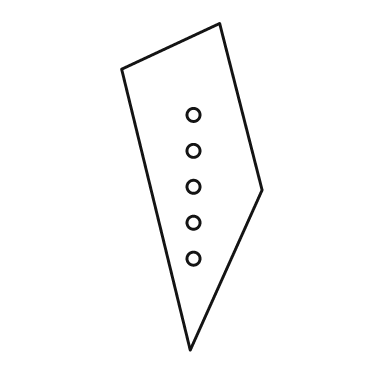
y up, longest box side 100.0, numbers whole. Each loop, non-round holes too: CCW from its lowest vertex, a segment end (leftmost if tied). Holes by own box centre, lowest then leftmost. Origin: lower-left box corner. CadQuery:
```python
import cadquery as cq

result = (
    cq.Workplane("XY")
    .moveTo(21.0, 0.0)
    .lineTo(43.0, 49.0)
    .lineTo(30.0, 100.0)
    .lineTo(0.0, 86.0)
    .close()
    .moveTo(22.0, 28.0)
    .circle(2.0)
    .moveTo(22.0, 39.0)
    .circle(2.0)
    .moveTo(22.0, 50.0)
    .circle(2.0)
    .moveTo(22.0, 61.0)
    .circle(2.0)
    .moveTo(22.0, 72.0)
    .circle(2.0)
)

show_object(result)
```